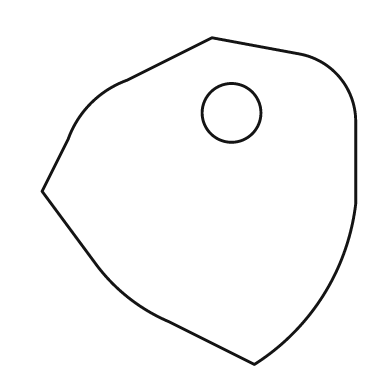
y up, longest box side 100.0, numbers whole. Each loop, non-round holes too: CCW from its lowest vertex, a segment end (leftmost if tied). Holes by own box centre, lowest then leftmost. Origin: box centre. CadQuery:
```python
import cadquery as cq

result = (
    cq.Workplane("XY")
    .moveTo(17.0, -50.0)
    .threePointArc((38.0, -29.0), (48.0, -1.0))
    .lineTo(48.0, 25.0)
    .threePointArc((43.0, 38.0), (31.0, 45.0))
    .lineTo(4.0, 50.0)
    .lineTo(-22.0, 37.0)
    .threePointArc((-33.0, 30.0), (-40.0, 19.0))
    .lineTo(-48.0, 3.0)
    .lineTo(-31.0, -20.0)
    .threePointArc((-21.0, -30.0), (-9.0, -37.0))
    .close()
    .moveTo(10.0, 27.0)
    .circle(9.0)
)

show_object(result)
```